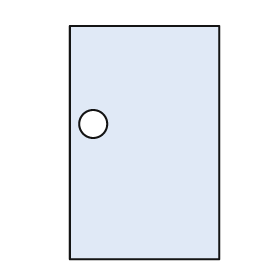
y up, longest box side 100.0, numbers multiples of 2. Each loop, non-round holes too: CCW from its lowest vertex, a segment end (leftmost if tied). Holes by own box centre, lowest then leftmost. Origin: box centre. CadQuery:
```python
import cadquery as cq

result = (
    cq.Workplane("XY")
    .moveTo(-32.0, -50.0)
    .lineTo(32.0, -50.0)
    .lineTo(32.0, 50.0)
    .lineTo(-32.0, 50.0)
    .close()
    .moveTo(-22.0, 8.0)
    .circle(6.0)
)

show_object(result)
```